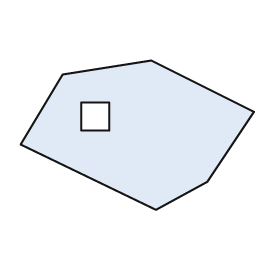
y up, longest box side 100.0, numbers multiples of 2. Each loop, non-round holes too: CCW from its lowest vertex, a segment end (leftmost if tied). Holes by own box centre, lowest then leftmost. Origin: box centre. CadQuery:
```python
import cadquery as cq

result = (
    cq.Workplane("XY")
    .moveTo(8.0, -32.0)
    .lineTo(30.0, -20.0)
    .lineTo(50.0, 10.0)
    .lineTo(6.0, 32.0)
    .lineTo(-32.0, 26.0)
    .lineTo(-50.0, -4.0)
    .close()
    .moveTo(-24.0, 2.0)
    .lineTo(-12.0, 2.0)
    .lineTo(-12.0, 14.0)
    .lineTo(-24.0, 14.0)
    .close()
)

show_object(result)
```